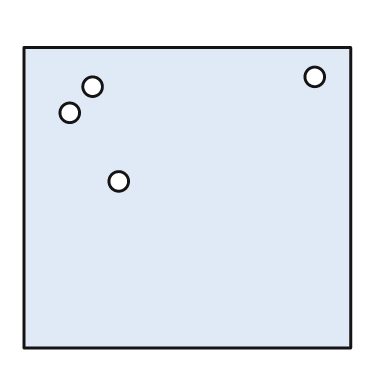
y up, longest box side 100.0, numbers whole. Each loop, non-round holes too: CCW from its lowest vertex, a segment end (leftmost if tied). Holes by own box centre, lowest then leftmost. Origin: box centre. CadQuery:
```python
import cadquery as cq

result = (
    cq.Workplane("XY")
    .moveTo(-50.0, -46.0)
    .lineTo(50.0, -46.0)
    .lineTo(50.0, 46.0)
    .lineTo(-50.0, 46.0)
    .close()
    .moveTo(-21.0, 5.0)
    .circle(3.0)
    .moveTo(-36.0, 26.0)
    .circle(3.0)
    .moveTo(-29.0, 34.0)
    .circle(3.0)
    .moveTo(39.0, 37.0)
    .circle(3.0)
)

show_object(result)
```